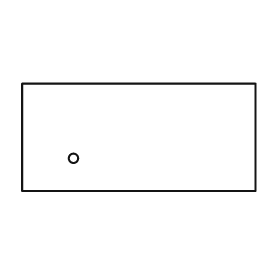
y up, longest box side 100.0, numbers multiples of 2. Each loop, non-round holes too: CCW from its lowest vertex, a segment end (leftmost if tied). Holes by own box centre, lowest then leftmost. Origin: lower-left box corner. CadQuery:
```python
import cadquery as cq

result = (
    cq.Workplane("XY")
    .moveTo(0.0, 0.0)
    .lineTo(100.0, 0.0)
    .lineTo(100.0, 46.0)
    .lineTo(0.0, 46.0)
    .close()
    .moveTo(22.0, 14.0)
    .circle(2.0)
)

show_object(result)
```